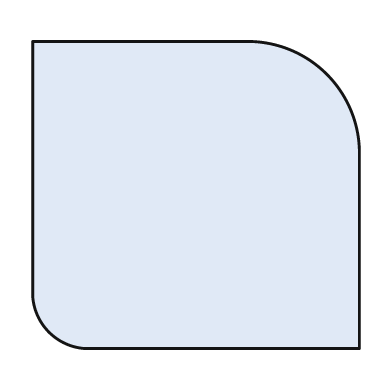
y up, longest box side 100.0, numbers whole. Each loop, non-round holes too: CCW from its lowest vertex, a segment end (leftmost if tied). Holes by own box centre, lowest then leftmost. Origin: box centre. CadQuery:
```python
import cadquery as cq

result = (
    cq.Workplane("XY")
    .moveTo(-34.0, -47.0)
    .lineTo(50.0, -47.0)
    .lineTo(50.0, 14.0)
    .threePointArc((40.0, 37.0), (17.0, 47.0))
    .lineTo(-50.0, 47.0)
    .lineTo(-50.0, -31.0)
    .threePointArc((-45.0, -42.0), (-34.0, -47.0))
    .close()
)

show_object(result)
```